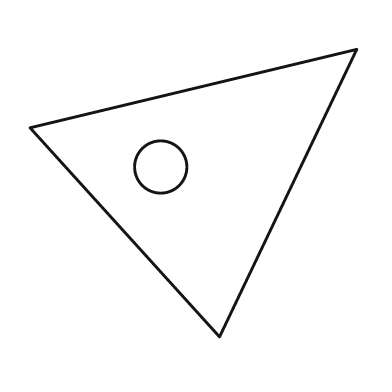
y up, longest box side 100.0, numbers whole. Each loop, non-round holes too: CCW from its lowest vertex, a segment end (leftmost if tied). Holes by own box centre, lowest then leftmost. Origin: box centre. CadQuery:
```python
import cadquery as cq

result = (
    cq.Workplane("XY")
    .moveTo(8.0, -44.0)
    .lineTo(50.0, 44.0)
    .lineTo(-50.0, 20.0)
    .close()
    .moveTo(-10.0, 8.0)
    .circle(8.0)
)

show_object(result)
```